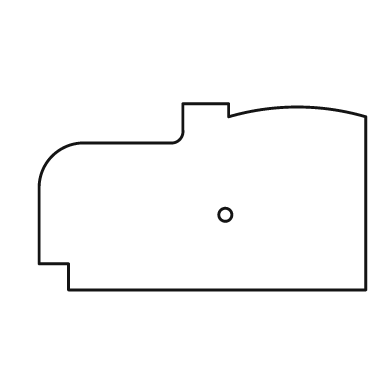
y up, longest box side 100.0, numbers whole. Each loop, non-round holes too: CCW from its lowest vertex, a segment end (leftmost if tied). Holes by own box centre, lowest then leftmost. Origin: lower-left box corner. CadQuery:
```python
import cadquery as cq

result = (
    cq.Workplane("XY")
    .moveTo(9.0, 0.0)
    .lineTo(100.0, 0.0)
    .lineTo(100.0, 53.0)
    .threePointArc((79.0, 56.0), (58.0, 53.0))
    .lineTo(58.0, 57.0)
    .lineTo(44.0, 57.0)
    .lineTo(44.0, 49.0)
    .threePointArc((43.0, 46.0), (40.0, 45.0))
    .lineTo(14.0, 45.0)
    .threePointArc((4.0, 41.0), (0.0, 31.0))
    .lineTo(0.0, 8.0)
    .lineTo(9.0, 8.0)
    .close()
    .moveTo(57.0, 23.0)
    .circle(2.0)
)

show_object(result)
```